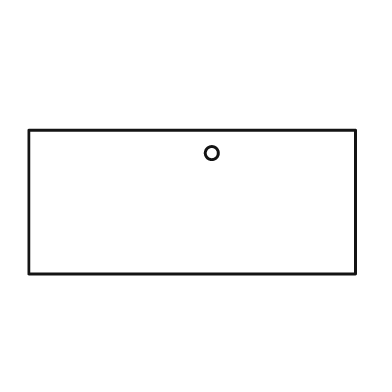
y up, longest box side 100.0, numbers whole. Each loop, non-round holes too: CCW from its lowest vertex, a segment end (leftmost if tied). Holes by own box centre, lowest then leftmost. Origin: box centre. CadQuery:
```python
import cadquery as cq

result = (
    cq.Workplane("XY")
    .moveTo(-50.0, -22.0)
    .lineTo(50.0, -22.0)
    .lineTo(50.0, 22.0)
    .lineTo(-50.0, 22.0)
    .close()
    .moveTo(6.0, 15.0)
    .circle(2.0)
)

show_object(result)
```